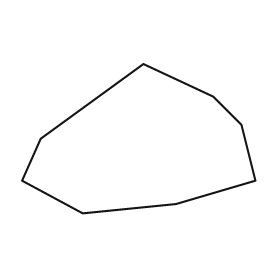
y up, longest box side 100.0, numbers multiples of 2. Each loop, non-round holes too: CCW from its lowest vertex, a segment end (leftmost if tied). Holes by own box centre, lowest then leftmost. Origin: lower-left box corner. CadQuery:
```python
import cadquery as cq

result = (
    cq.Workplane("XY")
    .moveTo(26.0, 0.0)
    .lineTo(66.0, 4.0)
    .lineTo(100.0, 14.0)
    .lineTo(94.0, 38.0)
    .lineTo(82.0, 50.0)
    .lineTo(52.0, 64.0)
    .lineTo(8.0, 32.0)
    .lineTo(0.0, 14.0)
    .close()
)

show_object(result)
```